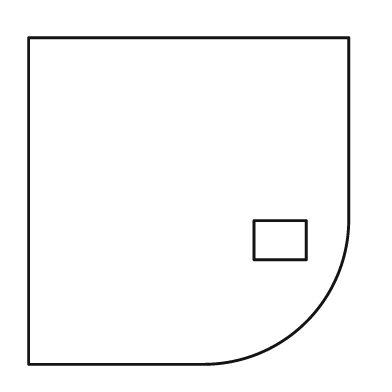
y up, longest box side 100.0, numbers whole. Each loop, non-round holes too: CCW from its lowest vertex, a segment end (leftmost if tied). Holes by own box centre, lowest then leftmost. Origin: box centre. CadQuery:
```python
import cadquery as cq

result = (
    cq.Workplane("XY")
    .moveTo(-49.0, -50.0)
    .lineTo(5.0, -50.0)
    .threePointArc((36.0, -37.0), (49.0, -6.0))
    .lineTo(49.0, 50.0)
    .lineTo(-49.0, 50.0)
    .close()
    .moveTo(20.0, -18.0)
    .lineTo(36.0, -18.0)
    .lineTo(36.0, -6.0)
    .lineTo(20.0, -6.0)
    .close()
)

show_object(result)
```